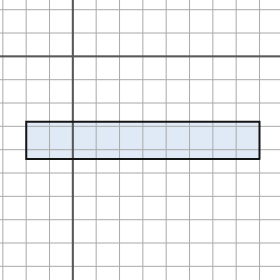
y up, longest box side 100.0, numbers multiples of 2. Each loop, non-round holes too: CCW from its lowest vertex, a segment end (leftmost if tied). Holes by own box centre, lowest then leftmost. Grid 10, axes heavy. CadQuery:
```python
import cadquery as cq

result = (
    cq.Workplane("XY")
    .moveTo(-20.0, -44.0)
    .lineTo(80.0, -44.0)
    .lineTo(80.0, -28.0)
    .lineTo(-20.0, -28.0)
    .close()
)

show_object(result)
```